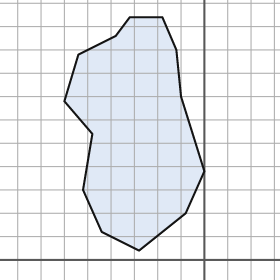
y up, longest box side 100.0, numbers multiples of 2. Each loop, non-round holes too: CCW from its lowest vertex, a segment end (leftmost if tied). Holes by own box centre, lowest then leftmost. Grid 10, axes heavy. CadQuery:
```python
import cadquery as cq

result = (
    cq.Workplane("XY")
    .moveTo(-28.0, 4.0)
    .lineTo(-8.0, 20.0)
    .lineTo(0.0, 38.0)
    .lineTo(-10.0, 70.0)
    .lineTo(-12.0, 90.0)
    .lineTo(-18.0, 104.0)
    .lineTo(-32.0, 104.0)
    .lineTo(-38.0, 96.0)
    .lineTo(-54.0, 88.0)
    .lineTo(-60.0, 68.0)
    .lineTo(-48.0, 54.0)
    .lineTo(-52.0, 30.0)
    .lineTo(-44.0, 12.0)
    .close()
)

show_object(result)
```